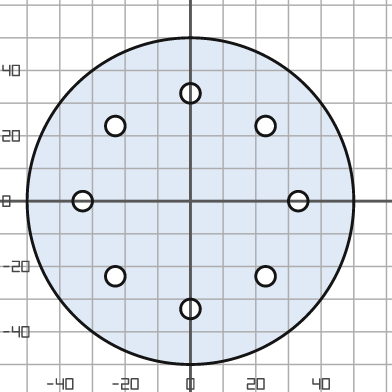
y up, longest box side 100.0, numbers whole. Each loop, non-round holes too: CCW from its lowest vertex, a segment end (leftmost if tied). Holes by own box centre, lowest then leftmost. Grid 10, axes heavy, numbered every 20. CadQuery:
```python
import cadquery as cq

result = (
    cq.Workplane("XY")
    .moveTo(0.0, 0.0)
    .circle(50.0)
    .moveTo(0.0, -33.0)
    .circle(3.0)
    .moveTo(-23.0, -23.0)
    .circle(3.0)
    .moveTo(23.0, -23.0)
    .circle(3.0)
    .moveTo(-33.0, 0.0)
    .circle(3.0)
    .moveTo(33.0, 0.0)
    .circle(3.0)
    .moveTo(-23.0, 23.0)
    .circle(3.0)
    .moveTo(23.0, 23.0)
    .circle(3.0)
    .moveTo(0.0, 33.0)
    .circle(3.0)
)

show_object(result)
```